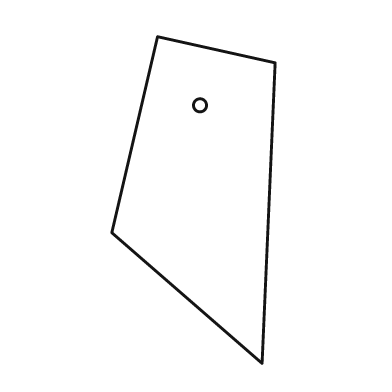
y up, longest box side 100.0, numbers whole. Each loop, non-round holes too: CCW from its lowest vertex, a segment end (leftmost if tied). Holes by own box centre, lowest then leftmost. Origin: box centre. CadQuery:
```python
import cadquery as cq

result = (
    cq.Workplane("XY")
    .moveTo(21.0, -50.0)
    .lineTo(25.0, 42.0)
    .lineTo(-11.0, 50.0)
    .lineTo(-25.0, -10.0)
    .close()
    .moveTo(2.0, 29.0)
    .circle(2.0)
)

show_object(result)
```